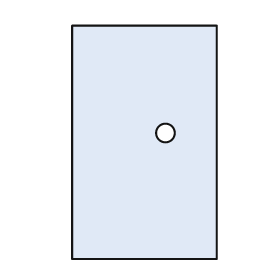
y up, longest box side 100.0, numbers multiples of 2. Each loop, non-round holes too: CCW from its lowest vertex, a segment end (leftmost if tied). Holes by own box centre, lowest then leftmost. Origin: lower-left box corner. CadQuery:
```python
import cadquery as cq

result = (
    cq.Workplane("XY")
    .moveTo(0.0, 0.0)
    .lineTo(62.0, 0.0)
    .lineTo(62.0, 100.0)
    .lineTo(0.0, 100.0)
    .close()
    .moveTo(40.0, 54.0)
    .circle(4.0)
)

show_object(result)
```